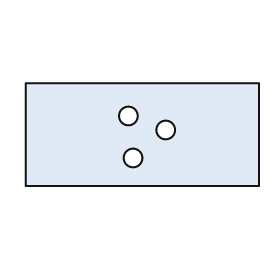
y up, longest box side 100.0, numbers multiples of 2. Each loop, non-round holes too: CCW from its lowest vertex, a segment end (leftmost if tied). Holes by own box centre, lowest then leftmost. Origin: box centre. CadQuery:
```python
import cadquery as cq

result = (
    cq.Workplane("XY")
    .moveTo(-50.0, -22.0)
    .lineTo(50.0, -22.0)
    .lineTo(50.0, 22.0)
    .lineTo(-50.0, 22.0)
    .close()
    .moveTo(-4.0, -10.0)
    .circle(4.0)
    .moveTo(10.0, 2.0)
    .circle(4.0)
    .moveTo(-6.0, 8.0)
    .circle(4.0)
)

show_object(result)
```